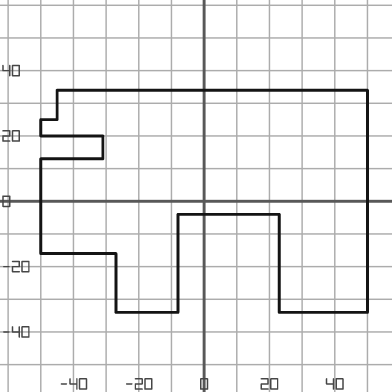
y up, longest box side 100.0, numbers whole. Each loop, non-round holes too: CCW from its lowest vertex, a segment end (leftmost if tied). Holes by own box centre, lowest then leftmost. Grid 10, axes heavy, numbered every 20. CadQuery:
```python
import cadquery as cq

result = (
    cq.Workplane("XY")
    .moveTo(-27.0, -34.0)
    .lineTo(-8.0, -34.0)
    .lineTo(-8.0, -4.0)
    .lineTo(23.0, -4.0)
    .lineTo(23.0, -34.0)
    .lineTo(50.0, -34.0)
    .lineTo(50.0, 34.0)
    .lineTo(-45.0, 34.0)
    .lineTo(-45.0, 25.0)
    .lineTo(-50.0, 25.0)
    .lineTo(-50.0, 20.0)
    .lineTo(-31.0, 20.0)
    .lineTo(-31.0, 13.0)
    .lineTo(-50.0, 13.0)
    .lineTo(-50.0, -16.0)
    .lineTo(-27.0, -16.0)
    .close()
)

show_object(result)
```